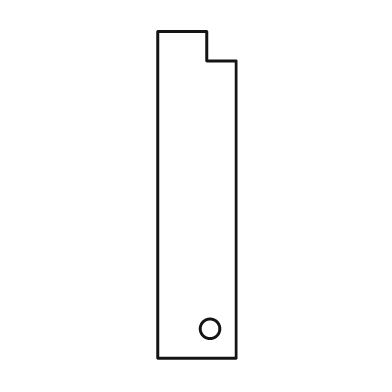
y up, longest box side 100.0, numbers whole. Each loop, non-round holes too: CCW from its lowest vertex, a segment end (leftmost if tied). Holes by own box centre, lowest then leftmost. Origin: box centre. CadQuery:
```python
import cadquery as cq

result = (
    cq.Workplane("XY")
    .moveTo(-12.0, -50.0)
    .lineTo(12.0, -50.0)
    .lineTo(12.0, 41.0)
    .lineTo(3.0, 41.0)
    .lineTo(3.0, 50.0)
    .lineTo(-12.0, 50.0)
    .close()
    .moveTo(4.0, -41.0)
    .circle(3.0)
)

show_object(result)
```